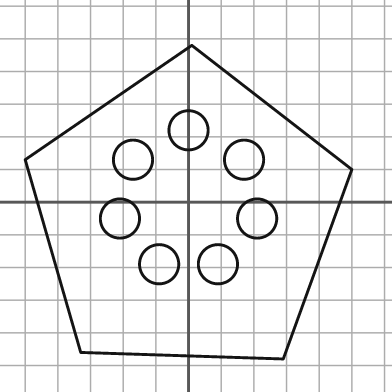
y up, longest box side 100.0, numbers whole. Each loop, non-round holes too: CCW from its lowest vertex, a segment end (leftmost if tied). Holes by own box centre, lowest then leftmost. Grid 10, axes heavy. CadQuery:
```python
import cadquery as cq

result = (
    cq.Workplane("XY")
    .moveTo(29.0, -48.0)
    .lineTo(50.0, 10.0)
    .lineTo(1.0, 48.0)
    .lineTo(-50.0, 13.0)
    .lineTo(-33.0, -46.0)
    .close()
    .moveTo(-9.0, -19.0)
    .circle(6.0)
    .moveTo(9.0, -19.0)
    .circle(6.0)
    .moveTo(-21.0, -5.0)
    .circle(6.0)
    .moveTo(21.0, -5.0)
    .circle(6.0)
    .moveTo(-17.0, 13.0)
    .circle(6.0)
    .moveTo(17.0, 13.0)
    .circle(6.0)
    .moveTo(0.0, 22.0)
    .circle(6.0)
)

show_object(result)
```